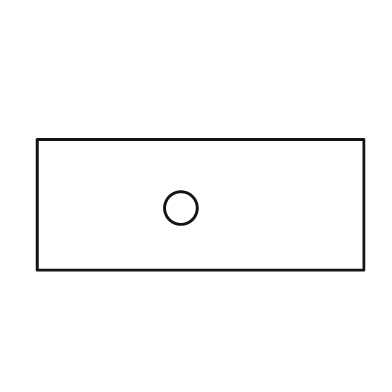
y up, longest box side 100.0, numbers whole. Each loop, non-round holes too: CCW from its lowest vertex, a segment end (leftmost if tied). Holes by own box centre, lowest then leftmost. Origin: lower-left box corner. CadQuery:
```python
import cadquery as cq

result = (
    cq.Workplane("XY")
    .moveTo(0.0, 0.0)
    .lineTo(100.0, 0.0)
    .lineTo(100.0, 40.0)
    .lineTo(0.0, 40.0)
    .close()
    .moveTo(44.0, 19.0)
    .circle(5.0)
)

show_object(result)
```